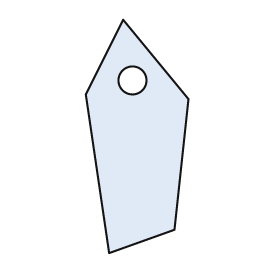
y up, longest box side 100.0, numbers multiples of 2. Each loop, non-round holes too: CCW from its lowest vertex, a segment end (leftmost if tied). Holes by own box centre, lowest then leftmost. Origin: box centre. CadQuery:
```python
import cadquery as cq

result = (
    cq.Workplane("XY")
    .moveTo(-12.0, -50.0)
    .lineTo(16.0, -40.0)
    .lineTo(22.0, 16.0)
    .lineTo(-6.0, 50.0)
    .lineTo(-22.0, 18.0)
    .close()
    .moveTo(-2.0, 24.0)
    .circle(6.0)
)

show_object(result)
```